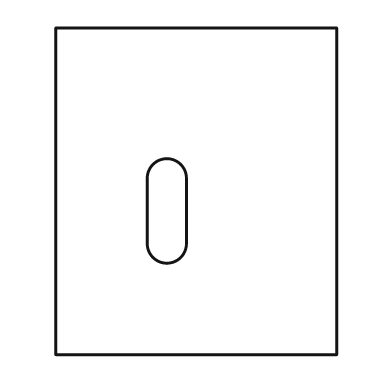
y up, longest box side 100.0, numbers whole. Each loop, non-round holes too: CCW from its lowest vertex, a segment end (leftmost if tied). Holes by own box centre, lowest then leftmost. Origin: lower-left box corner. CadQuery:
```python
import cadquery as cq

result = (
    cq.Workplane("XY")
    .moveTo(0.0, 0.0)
    .lineTo(86.0, 0.0)
    .lineTo(86.0, 100.0)
    .lineTo(0.0, 100.0)
    .close()
    .moveTo(28.0, 34.0)
    .threePointArc((34.0, 28.0), (40.0, 34.0))
    .lineTo(40.0, 54.0)
    .threePointArc((34.0, 60.0), (28.0, 54.0))
    .close()
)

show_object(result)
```